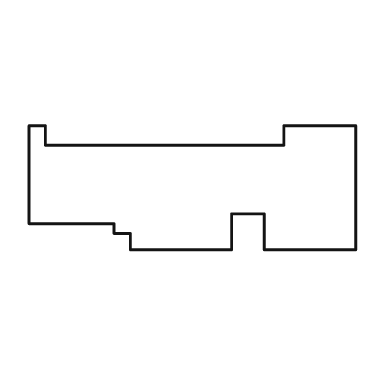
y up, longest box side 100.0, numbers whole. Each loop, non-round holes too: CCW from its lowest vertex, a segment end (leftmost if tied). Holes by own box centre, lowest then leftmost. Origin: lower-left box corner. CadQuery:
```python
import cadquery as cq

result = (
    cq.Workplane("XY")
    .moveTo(31.0, 0.0)
    .lineTo(62.0, 0.0)
    .lineTo(62.0, 11.0)
    .lineTo(72.0, 11.0)
    .lineTo(72.0, 0.0)
    .lineTo(100.0, 0.0)
    .lineTo(100.0, 38.0)
    .lineTo(78.0, 38.0)
    .lineTo(78.0, 32.0)
    .lineTo(5.0, 32.0)
    .lineTo(5.0, 38.0)
    .lineTo(0.0, 38.0)
    .lineTo(0.0, 8.0)
    .lineTo(26.0, 8.0)
    .lineTo(26.0, 5.0)
    .lineTo(31.0, 5.0)
    .close()
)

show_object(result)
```